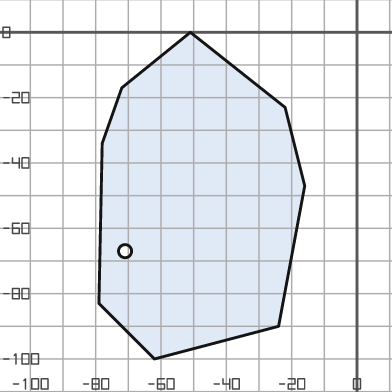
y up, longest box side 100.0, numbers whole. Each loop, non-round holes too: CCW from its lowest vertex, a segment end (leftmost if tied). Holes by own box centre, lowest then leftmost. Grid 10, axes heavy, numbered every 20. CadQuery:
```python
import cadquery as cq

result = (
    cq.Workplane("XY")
    .moveTo(-62.0, -100.0)
    .lineTo(-24.0, -90.0)
    .lineTo(-16.0, -47.0)
    .lineTo(-22.0, -23.0)
    .lineTo(-51.0, 0.0)
    .lineTo(-72.0, -17.0)
    .lineTo(-78.0, -34.0)
    .lineTo(-79.0, -83.0)
    .close()
    .moveTo(-71.0, -67.0)
    .circle(2.0)
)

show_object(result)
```